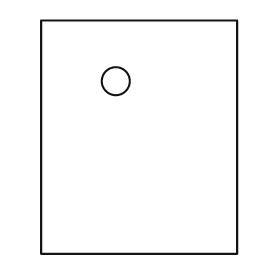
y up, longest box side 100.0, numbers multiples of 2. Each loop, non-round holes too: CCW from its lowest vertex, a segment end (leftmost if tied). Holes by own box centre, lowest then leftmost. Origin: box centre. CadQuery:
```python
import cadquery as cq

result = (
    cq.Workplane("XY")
    .moveTo(-42.0, -50.0)
    .lineTo(42.0, -50.0)
    .lineTo(42.0, 50.0)
    .lineTo(-42.0, 50.0)
    .close()
    .moveTo(-10.0, 24.0)
    .circle(6.0)
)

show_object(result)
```